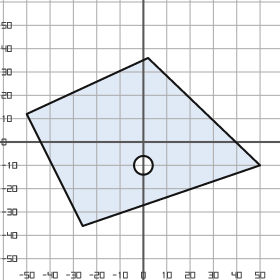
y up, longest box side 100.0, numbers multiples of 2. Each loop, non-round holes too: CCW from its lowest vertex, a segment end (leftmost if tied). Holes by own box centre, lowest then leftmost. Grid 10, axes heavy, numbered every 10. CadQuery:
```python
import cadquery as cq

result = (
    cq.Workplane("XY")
    .moveTo(-26.0, -36.0)
    .lineTo(50.0, -10.0)
    .lineTo(2.0, 36.0)
    .lineTo(-50.0, 12.0)
    .close()
    .moveTo(0.0, -10.0)
    .circle(4.0)
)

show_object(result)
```